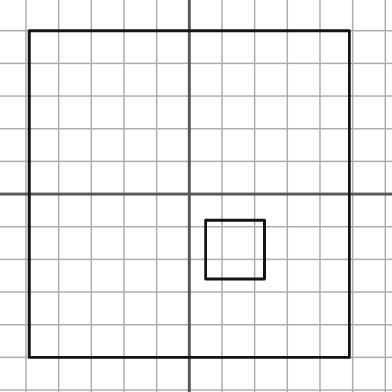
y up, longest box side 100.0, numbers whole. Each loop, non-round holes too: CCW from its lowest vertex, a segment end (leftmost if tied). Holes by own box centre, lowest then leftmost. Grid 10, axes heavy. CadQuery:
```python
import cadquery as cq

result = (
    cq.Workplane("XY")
    .moveTo(-49.0, -50.0)
    .lineTo(49.0, -50.0)
    .lineTo(49.0, 50.0)
    .lineTo(-49.0, 50.0)
    .close()
    .moveTo(5.0, -26.0)
    .lineTo(23.0, -26.0)
    .lineTo(23.0, -8.0)
    .lineTo(5.0, -8.0)
    .close()
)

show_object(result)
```